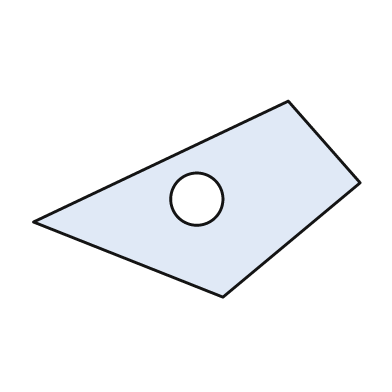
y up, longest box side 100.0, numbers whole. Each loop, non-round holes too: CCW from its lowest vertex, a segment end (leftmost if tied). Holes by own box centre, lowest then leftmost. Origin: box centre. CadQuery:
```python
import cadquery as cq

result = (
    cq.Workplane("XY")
    .moveTo(8.0, -30.0)
    .lineTo(50.0, 5.0)
    .lineTo(28.0, 30.0)
    .lineTo(-50.0, -7.0)
    .close()
    .moveTo(0.0, 0.0)
    .circle(8.0)
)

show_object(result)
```